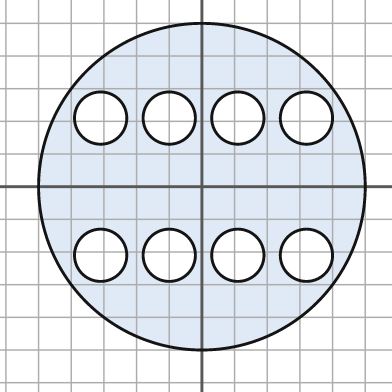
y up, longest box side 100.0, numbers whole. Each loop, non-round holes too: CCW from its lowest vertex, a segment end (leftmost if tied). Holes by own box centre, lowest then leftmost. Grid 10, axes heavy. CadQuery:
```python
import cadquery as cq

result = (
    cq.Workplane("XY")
    .moveTo(0.0, 0.0)
    .circle(50.0)
    .moveTo(-31.0, -21.0)
    .circle(8.0)
    .moveTo(-10.0, -21.0)
    .circle(8.0)
    .moveTo(11.0, -21.0)
    .circle(8.0)
    .moveTo(32.0, -21.0)
    .circle(8.0)
    .moveTo(-31.0, 21.0)
    .circle(8.0)
    .moveTo(-10.0, 21.0)
    .circle(8.0)
    .moveTo(11.0, 21.0)
    .circle(8.0)
    .moveTo(32.0, 21.0)
    .circle(8.0)
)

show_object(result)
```